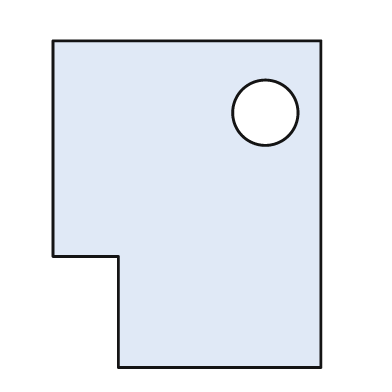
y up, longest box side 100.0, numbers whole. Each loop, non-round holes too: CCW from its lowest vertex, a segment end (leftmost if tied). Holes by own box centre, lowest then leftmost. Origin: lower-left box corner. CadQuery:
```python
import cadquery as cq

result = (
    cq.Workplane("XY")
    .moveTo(20.0, 0.0)
    .lineTo(82.0, 0.0)
    .lineTo(82.0, 100.0)
    .lineTo(0.0, 100.0)
    .lineTo(0.0, 34.0)
    .lineTo(20.0, 34.0)
    .close()
    .moveTo(65.0, 78.0)
    .circle(10.0)
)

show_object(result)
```